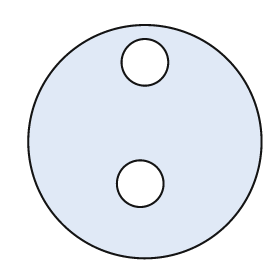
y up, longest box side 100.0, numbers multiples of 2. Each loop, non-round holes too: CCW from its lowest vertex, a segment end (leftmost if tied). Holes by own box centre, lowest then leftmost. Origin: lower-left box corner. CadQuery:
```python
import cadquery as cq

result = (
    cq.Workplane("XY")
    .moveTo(50.0, 50.0)
    .circle(50.0)
    .moveTo(48.0, 32.0)
    .circle(10.0)
    .moveTo(50.0, 84.0)
    .circle(10.0)
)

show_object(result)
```